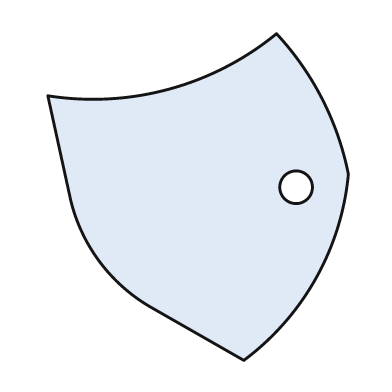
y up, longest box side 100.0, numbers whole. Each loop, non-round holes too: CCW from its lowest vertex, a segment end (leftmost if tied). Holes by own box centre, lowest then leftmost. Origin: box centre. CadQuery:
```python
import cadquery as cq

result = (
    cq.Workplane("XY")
    .moveTo(14.0, -50.0)
    .threePointArc((36.0, -25.0), (46.0, 7.0))
    .threePointArc((38.0, 30.0), (24.0, 50.0))
    .threePointArc((-9.0, 33.0), (-46.0, 31.0))
    .lineTo(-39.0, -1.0)
    .threePointArc((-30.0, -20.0), (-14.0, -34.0))
    .close()
    .moveTo(30.0, 3.0)
    .circle(5.0)
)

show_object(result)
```